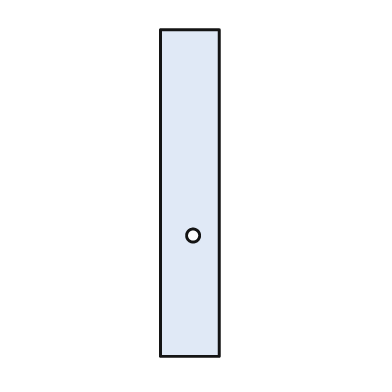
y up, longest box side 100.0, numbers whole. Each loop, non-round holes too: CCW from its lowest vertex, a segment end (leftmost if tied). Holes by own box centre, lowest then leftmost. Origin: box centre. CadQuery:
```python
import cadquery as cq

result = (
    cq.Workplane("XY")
    .moveTo(-9.0, -50.0)
    .lineTo(9.0, -50.0)
    .lineTo(9.0, 50.0)
    .lineTo(-9.0, 50.0)
    .close()
    .moveTo(1.0, -13.0)
    .circle(2.0)
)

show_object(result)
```